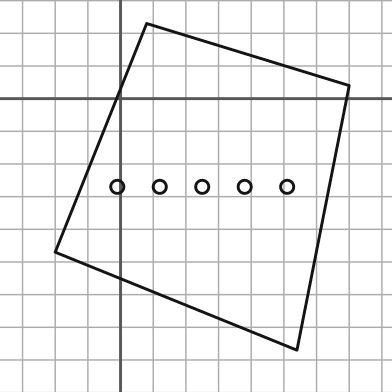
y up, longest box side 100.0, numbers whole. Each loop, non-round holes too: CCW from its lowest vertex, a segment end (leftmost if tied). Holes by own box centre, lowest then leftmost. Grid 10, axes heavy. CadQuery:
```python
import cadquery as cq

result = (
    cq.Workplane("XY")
    .moveTo(54.0, -77.0)
    .lineTo(70.0, 4.0)
    .lineTo(8.0, 23.0)
    .lineTo(-20.0, -47.0)
    .close()
    .moveTo(-1.0, -27.0)
    .circle(2.0)
    .moveTo(12.0, -27.0)
    .circle(2.0)
    .moveTo(25.0, -27.0)
    .circle(2.0)
    .moveTo(38.0, -27.0)
    .circle(2.0)
    .moveTo(51.0, -27.0)
    .circle(2.0)
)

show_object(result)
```